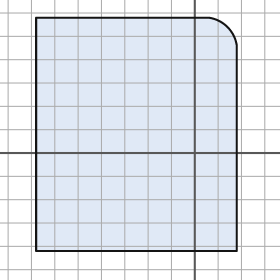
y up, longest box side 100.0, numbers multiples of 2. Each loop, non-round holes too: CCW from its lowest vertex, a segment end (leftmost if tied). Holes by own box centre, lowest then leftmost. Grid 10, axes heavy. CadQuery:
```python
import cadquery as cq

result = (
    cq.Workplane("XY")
    .moveTo(-68.0, -42.0)
    .lineTo(18.0, -42.0)
    .lineTo(18.0, 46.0)
    .threePointArc((14.0, 54.0), (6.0, 58.0))
    .lineTo(-68.0, 58.0)
    .close()
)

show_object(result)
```